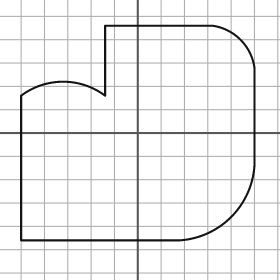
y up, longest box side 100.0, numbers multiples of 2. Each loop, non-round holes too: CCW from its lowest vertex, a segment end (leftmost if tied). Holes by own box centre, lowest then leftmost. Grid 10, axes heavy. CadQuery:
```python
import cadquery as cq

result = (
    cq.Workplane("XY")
    .moveTo(-50.0, -46.0)
    .lineTo(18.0, -46.0)
    .threePointArc((40.0, -36.0), (50.0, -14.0))
    .lineTo(50.0, 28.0)
    .threePointArc((44.0, 40.0), (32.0, 46.0))
    .lineTo(-14.0, 46.0)
    .lineTo(-14.0, 16.0)
    .threePointArc((-32.0, 22.0), (-50.0, 16.0))
    .close()
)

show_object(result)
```